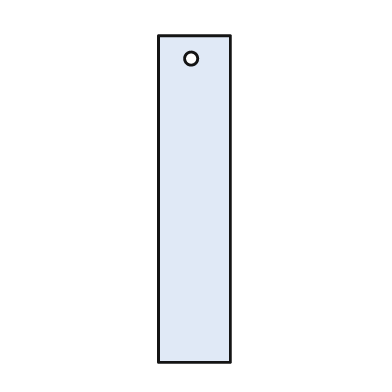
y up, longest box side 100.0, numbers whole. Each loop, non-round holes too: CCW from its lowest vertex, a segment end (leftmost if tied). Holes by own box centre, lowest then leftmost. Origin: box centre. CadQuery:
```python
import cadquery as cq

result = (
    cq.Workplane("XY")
    .moveTo(-11.0, -50.0)
    .lineTo(11.0, -50.0)
    .lineTo(11.0, 50.0)
    .lineTo(-11.0, 50.0)
    .close()
    .moveTo(-1.0, 43.0)
    .circle(2.0)
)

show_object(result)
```